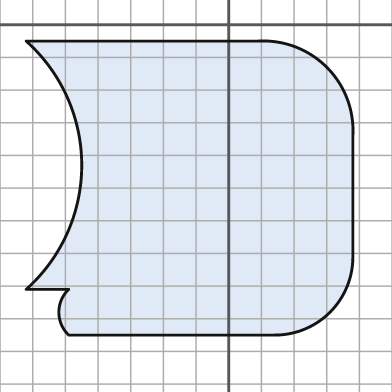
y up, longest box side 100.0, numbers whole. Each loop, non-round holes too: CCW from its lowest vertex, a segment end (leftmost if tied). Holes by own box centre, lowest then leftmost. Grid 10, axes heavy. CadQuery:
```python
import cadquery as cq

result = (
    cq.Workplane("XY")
    .moveTo(-49.0, -95.0)
    .lineTo(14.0, -95.0)
    .threePointArc((31.0, -88.0), (38.0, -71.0))
    .lineTo(38.0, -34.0)
    .threePointArc((30.0, -13.0), (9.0, -5.0))
    .lineTo(-62.0, -5.0)
    .threePointArc((-45.0, -43.0), (-62.0, -81.0))
    .lineTo(-49.0, -81.0)
    .threePointArc((-52.0, -88.0), (-49.0, -95.0))
    .close()
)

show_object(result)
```